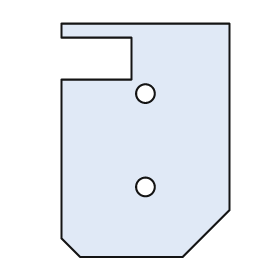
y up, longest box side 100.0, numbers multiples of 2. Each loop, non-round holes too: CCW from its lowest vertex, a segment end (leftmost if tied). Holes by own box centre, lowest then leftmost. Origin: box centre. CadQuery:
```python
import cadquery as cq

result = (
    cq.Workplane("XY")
    .moveTo(-28.0, -50.0)
    .lineTo(16.0, -50.0)
    .lineTo(36.0, -30.0)
    .lineTo(36.0, 50.0)
    .lineTo(-36.0, 50.0)
    .lineTo(-36.0, 44.0)
    .lineTo(-6.0, 44.0)
    .lineTo(-6.0, 26.0)
    .lineTo(-36.0, 26.0)
    .lineTo(-36.0, -42.0)
    .close()
    .moveTo(0.0, -20.0)
    .circle(4.0)
    .moveTo(0.0, 20.0)
    .circle(4.0)
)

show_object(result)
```